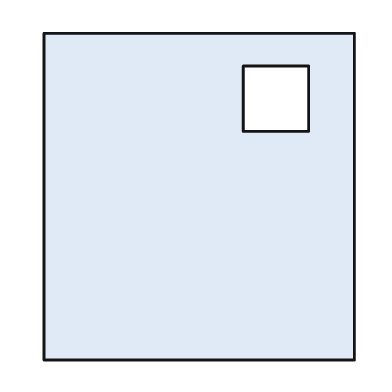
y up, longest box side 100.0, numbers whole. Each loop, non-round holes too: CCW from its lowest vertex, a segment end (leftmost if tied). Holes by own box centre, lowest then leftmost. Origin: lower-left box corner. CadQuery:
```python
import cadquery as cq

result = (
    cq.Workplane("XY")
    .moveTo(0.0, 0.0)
    .lineTo(95.0, 0.0)
    .lineTo(95.0, 100.0)
    .lineTo(0.0, 100.0)
    .close()
    .moveTo(61.0, 70.0)
    .lineTo(81.0, 70.0)
    .lineTo(81.0, 90.0)
    .lineTo(61.0, 90.0)
    .close()
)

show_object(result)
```